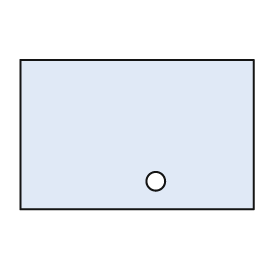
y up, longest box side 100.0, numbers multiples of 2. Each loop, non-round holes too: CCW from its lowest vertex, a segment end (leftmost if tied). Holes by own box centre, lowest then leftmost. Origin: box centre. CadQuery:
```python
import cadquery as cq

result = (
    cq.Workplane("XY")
    .moveTo(-50.0, -32.0)
    .lineTo(50.0, -32.0)
    .lineTo(50.0, 32.0)
    .lineTo(-50.0, 32.0)
    .close()
    .moveTo(8.0, -20.0)
    .circle(4.0)
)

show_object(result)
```